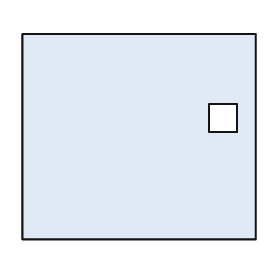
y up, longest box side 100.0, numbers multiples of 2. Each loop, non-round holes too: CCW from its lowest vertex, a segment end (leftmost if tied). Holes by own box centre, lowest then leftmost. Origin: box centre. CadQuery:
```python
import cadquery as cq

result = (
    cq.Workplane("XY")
    .moveTo(-50.0, -44.0)
    .lineTo(50.0, -44.0)
    .lineTo(50.0, 44.0)
    .lineTo(-50.0, 44.0)
    .close()
    .moveTo(30.0, 2.0)
    .lineTo(42.0, 2.0)
    .lineTo(42.0, 14.0)
    .lineTo(30.0, 14.0)
    .close()
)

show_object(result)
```